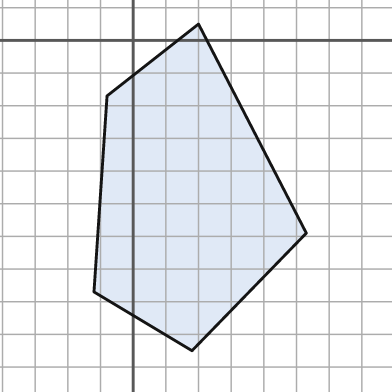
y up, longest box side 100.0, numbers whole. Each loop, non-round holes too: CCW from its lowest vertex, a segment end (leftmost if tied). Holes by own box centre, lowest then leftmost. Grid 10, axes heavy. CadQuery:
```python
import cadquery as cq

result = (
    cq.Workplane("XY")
    .moveTo(18.0, -95.0)
    .lineTo(53.0, -59.0)
    .lineTo(20.0, 5.0)
    .lineTo(-8.0, -17.0)
    .lineTo(-12.0, -77.0)
    .close()
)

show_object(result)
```